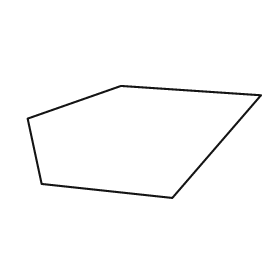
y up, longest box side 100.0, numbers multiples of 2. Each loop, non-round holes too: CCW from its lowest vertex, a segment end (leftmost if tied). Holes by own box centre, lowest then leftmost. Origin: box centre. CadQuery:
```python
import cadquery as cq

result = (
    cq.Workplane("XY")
    .moveTo(12.0, -24.0)
    .lineTo(50.0, 20.0)
    .lineTo(-10.0, 24.0)
    .lineTo(-50.0, 10.0)
    .lineTo(-44.0, -18.0)
    .close()
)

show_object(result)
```